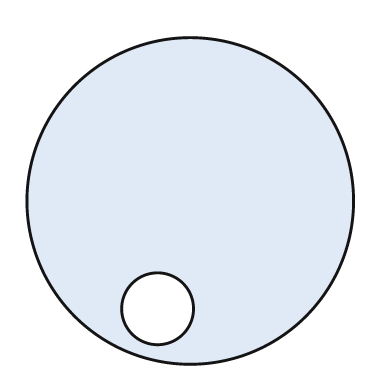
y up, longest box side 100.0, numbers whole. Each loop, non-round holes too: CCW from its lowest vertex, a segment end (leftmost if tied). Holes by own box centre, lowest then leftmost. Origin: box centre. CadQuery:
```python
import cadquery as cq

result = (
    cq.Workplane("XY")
    .moveTo(0.0, 0.0)
    .circle(50.0)
    .moveTo(-10.0, -33.0)
    .circle(11.0)
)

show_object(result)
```